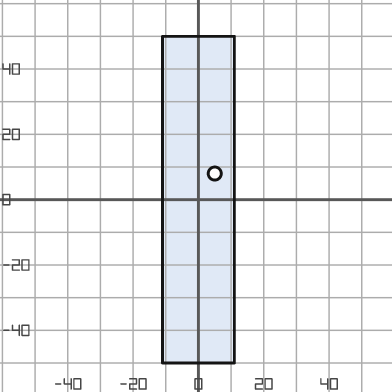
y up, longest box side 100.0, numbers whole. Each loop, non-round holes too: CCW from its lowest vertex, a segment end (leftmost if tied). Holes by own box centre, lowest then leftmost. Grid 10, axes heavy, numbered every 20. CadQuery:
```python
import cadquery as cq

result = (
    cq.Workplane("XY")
    .moveTo(-11.0, -50.0)
    .lineTo(11.0, -50.0)
    .lineTo(11.0, 50.0)
    .lineTo(-11.0, 50.0)
    .close()
    .moveTo(5.0, 8.0)
    .circle(2.0)
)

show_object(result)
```